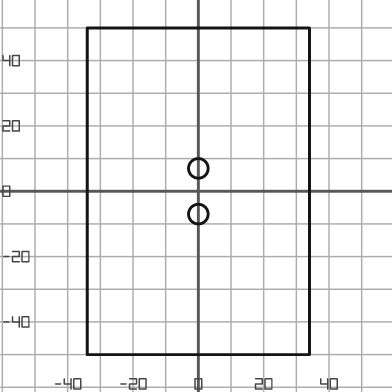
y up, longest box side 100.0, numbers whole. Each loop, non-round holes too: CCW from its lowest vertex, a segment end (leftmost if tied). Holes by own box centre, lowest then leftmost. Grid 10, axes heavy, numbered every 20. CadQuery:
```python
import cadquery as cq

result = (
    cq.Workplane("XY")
    .moveTo(-34.0, -50.0)
    .lineTo(34.0, -50.0)
    .lineTo(34.0, 50.0)
    .lineTo(-34.0, 50.0)
    .close()
    .moveTo(0.0, -7.0)
    .circle(3.0)
    .moveTo(0.0, 7.0)
    .circle(3.0)
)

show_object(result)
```